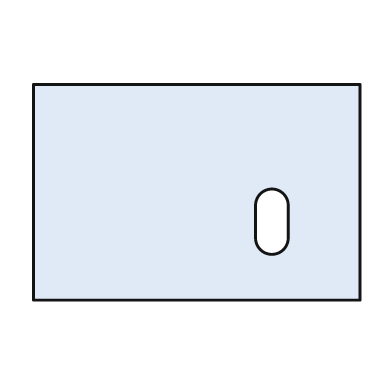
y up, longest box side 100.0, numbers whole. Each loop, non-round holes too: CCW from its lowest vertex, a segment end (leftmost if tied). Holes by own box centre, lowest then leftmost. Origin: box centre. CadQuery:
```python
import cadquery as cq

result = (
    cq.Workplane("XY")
    .moveTo(-50.0, -33.0)
    .lineTo(50.0, -33.0)
    .lineTo(50.0, 33.0)
    .lineTo(-50.0, 33.0)
    .close()
    .moveTo(18.0, -14.0)
    .threePointArc((23.0, -19.0), (28.0, -14.0))
    .lineTo(28.0, -4.0)
    .threePointArc((23.0, 1.0), (18.0, -4.0))
    .close()
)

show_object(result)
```